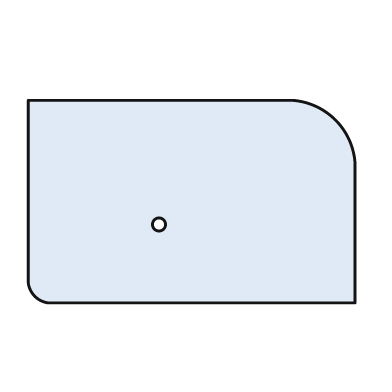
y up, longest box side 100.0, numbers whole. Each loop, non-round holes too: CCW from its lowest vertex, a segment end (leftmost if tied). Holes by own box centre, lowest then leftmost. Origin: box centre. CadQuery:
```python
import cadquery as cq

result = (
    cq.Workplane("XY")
    .moveTo(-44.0, -31.0)
    .lineTo(50.0, -31.0)
    .lineTo(50.0, 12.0)
    .threePointArc((44.0, 25.0), (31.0, 31.0))
    .lineTo(-50.0, 31.0)
    .lineTo(-50.0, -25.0)
    .threePointArc((-48.0, -29.0), (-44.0, -31.0))
    .close()
    .moveTo(-10.0, -7.0)
    .circle(2.0)
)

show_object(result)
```